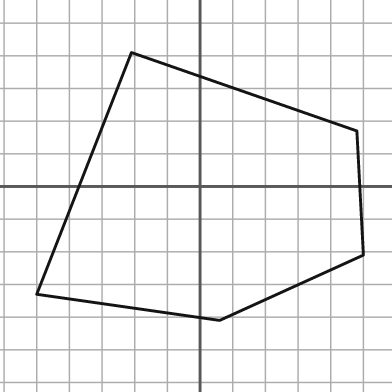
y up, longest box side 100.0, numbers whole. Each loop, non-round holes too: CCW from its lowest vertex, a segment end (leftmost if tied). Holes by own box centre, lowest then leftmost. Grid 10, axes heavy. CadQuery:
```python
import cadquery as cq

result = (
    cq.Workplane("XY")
    .moveTo(6.0, -41.0)
    .lineTo(50.0, -21.0)
    .lineTo(48.0, 17.0)
    .lineTo(-21.0, 41.0)
    .lineTo(-50.0, -33.0)
    .close()
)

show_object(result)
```